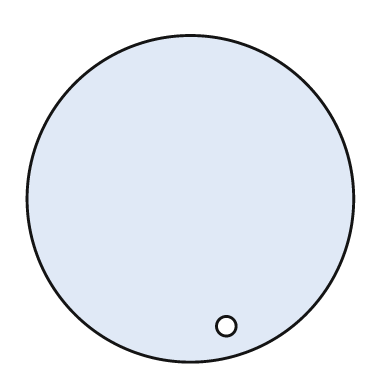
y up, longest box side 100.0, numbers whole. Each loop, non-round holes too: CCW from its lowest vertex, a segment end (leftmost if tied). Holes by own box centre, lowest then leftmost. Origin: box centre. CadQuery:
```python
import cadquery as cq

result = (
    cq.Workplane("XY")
    .moveTo(0.0, 0.0)
    .circle(50.0)
    .moveTo(11.0, -39.0)
    .circle(3.0)
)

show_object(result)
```